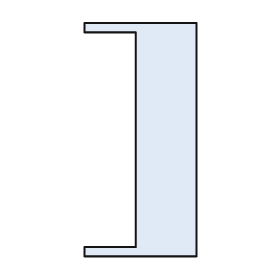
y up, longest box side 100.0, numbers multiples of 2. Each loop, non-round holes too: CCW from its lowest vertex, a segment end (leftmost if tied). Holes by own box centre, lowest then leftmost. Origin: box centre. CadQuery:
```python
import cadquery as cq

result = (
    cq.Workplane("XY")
    .moveTo(-24.0, -50.0)
    .lineTo(24.0, -50.0)
    .lineTo(24.0, 50.0)
    .lineTo(-24.0, 50.0)
    .lineTo(-24.0, 46.0)
    .lineTo(-2.0, 46.0)
    .lineTo(-2.0, -46.0)
    .lineTo(-24.0, -46.0)
    .close()
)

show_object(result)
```